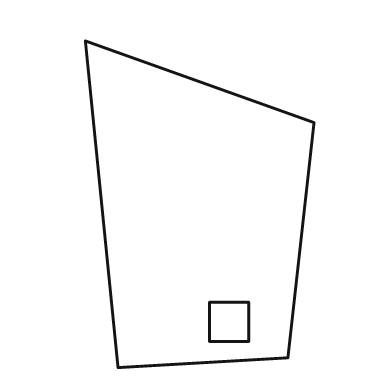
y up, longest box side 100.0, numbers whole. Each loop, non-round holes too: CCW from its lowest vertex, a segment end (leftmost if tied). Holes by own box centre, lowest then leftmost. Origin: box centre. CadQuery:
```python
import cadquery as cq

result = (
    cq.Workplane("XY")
    .moveTo(-25.0, -50.0)
    .lineTo(27.0, -47.0)
    .lineTo(35.0, 25.0)
    .lineTo(-35.0, 50.0)
    .close()
    .moveTo(3.0, -42.0)
    .lineTo(15.0, -42.0)
    .lineTo(15.0, -30.0)
    .lineTo(3.0, -30.0)
    .close()
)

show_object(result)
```